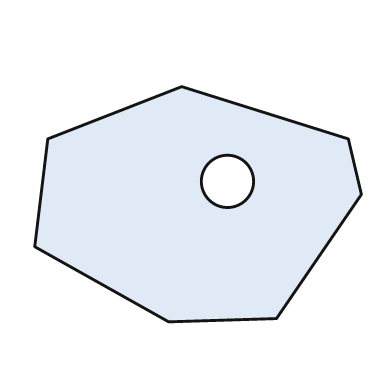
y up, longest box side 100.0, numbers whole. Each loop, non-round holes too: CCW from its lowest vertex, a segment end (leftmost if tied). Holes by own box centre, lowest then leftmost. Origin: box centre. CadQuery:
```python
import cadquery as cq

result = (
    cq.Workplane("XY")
    .moveTo(-9.0, -36.0)
    .lineTo(24.0, -35.0)
    .lineTo(50.0, 3.0)
    .lineTo(46.0, 20.0)
    .lineTo(-5.0, 36.0)
    .lineTo(-46.0, 20.0)
    .lineTo(-50.0, -13.0)
    .close()
    .moveTo(9.0, 7.0)
    .circle(8.0)
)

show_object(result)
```